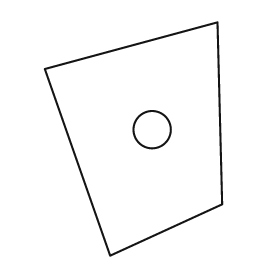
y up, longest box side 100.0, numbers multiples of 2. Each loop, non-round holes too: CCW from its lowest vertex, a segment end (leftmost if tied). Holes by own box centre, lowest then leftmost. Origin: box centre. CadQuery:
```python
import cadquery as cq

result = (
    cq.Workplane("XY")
    .moveTo(-10.0, -50.0)
    .lineTo(38.0, -28.0)
    .lineTo(36.0, 50.0)
    .lineTo(-38.0, 30.0)
    .close()
    .moveTo(8.0, 4.0)
    .circle(8.0)
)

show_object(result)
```